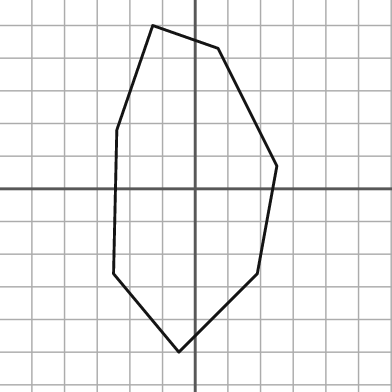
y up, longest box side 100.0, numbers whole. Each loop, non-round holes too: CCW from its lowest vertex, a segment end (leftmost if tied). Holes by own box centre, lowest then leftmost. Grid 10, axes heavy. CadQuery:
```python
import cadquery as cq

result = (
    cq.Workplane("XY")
    .moveTo(-5.0, -50.0)
    .lineTo(19.0, -26.0)
    .lineTo(25.0, 7.0)
    .lineTo(7.0, 43.0)
    .lineTo(-13.0, 50.0)
    .lineTo(-24.0, 18.0)
    .lineTo(-25.0, -26.0)
    .close()
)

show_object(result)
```